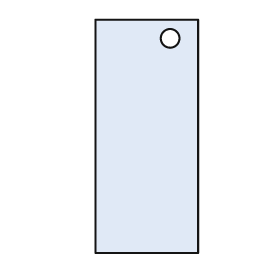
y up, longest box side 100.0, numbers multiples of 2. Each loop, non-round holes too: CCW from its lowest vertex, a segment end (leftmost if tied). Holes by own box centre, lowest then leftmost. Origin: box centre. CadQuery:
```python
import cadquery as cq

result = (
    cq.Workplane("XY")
    .moveTo(-22.0, -50.0)
    .lineTo(22.0, -50.0)
    .lineTo(22.0, 50.0)
    .lineTo(-22.0, 50.0)
    .close()
    .moveTo(10.0, 42.0)
    .circle(4.0)
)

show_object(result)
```